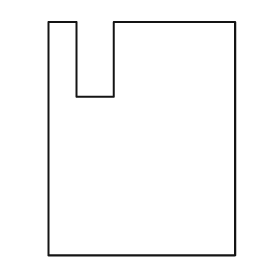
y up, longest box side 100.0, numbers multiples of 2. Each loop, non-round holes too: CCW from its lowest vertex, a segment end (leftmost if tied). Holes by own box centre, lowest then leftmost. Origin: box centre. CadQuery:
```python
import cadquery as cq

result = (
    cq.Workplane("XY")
    .moveTo(-40.0, -50.0)
    .lineTo(40.0, -50.0)
    .lineTo(40.0, 50.0)
    .lineTo(-12.0, 50.0)
    .lineTo(-12.0, 18.0)
    .lineTo(-28.0, 18.0)
    .lineTo(-28.0, 50.0)
    .lineTo(-40.0, 50.0)
    .close()
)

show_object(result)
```